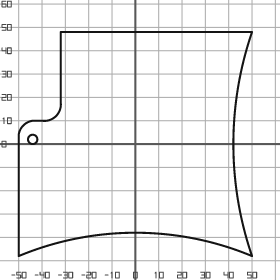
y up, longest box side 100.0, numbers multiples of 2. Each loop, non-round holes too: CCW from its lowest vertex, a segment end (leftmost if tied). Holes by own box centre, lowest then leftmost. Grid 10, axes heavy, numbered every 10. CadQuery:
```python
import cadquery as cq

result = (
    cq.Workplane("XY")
    .moveTo(-50.0, -48.0)
    .threePointArc((0.0, -38.0), (50.0, -48.0))
    .threePointArc((42.0, 0.0), (50.0, 48.0))
    .lineTo(-32.0, 48.0)
    .lineTo(-32.0, 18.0)
    .threePointArc((-34.0, 12.0), (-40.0, 10.0))
    .lineTo(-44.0, 10.0)
    .threePointArc((-48.0, 8.0), (-50.0, 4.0))
    .close()
    .moveTo(-44.0, 2.0)
    .circle(2.0)
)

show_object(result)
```